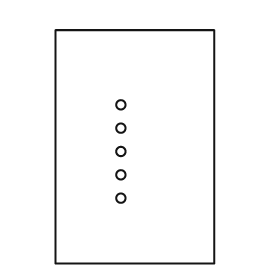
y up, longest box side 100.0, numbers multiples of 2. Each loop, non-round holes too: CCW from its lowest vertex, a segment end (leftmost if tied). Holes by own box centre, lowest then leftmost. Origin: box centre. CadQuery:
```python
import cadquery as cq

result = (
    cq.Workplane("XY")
    .moveTo(-34.0, -50.0)
    .lineTo(34.0, -50.0)
    .lineTo(34.0, 50.0)
    .lineTo(-34.0, 50.0)
    .close()
    .moveTo(-6.0, -22.0)
    .circle(2.0)
    .moveTo(-6.0, -12.0)
    .circle(2.0)
    .moveTo(-6.0, -2.0)
    .circle(2.0)
    .moveTo(-6.0, 8.0)
    .circle(2.0)
    .moveTo(-6.0, 18.0)
    .circle(2.0)
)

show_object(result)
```